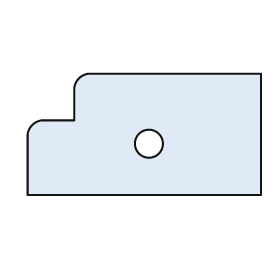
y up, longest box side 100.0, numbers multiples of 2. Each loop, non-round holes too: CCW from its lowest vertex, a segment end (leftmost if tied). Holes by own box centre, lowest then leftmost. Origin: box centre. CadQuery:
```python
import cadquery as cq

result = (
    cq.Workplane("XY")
    .moveTo(-50.0, -26.0)
    .lineTo(50.0, -26.0)
    .lineTo(50.0, 26.0)
    .lineTo(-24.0, 26.0)
    .threePointArc((-28.0, 24.0), (-30.0, 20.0))
    .lineTo(-30.0, 6.0)
    .lineTo(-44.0, 6.0)
    .threePointArc((-48.0, 4.0), (-50.0, 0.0))
    .close()
    .moveTo(2.0, -4.0)
    .circle(6.0)
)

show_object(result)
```